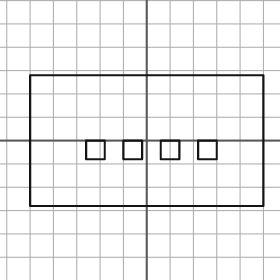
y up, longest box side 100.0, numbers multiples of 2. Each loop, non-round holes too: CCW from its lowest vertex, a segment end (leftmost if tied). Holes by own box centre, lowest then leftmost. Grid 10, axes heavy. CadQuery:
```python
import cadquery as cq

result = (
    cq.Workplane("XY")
    .moveTo(-50.0, -28.0)
    .lineTo(50.0, -28.0)
    .lineTo(50.0, 28.0)
    .lineTo(-50.0, 28.0)
    .close()
    .moveTo(-26.0, -8.0)
    .lineTo(-18.0, -8.0)
    .lineTo(-18.0, 0.0)
    .lineTo(-26.0, 0.0)
    .close()
    .moveTo(-10.0, -8.0)
    .lineTo(-2.0, -8.0)
    .lineTo(-2.0, 0.0)
    .lineTo(-10.0, 0.0)
    .close()
    .moveTo(6.0, -8.0)
    .lineTo(14.0, -8.0)
    .lineTo(14.0, 0.0)
    .lineTo(6.0, 0.0)
    .close()
    .moveTo(22.0, -8.0)
    .lineTo(30.0, -8.0)
    .lineTo(30.0, 0.0)
    .lineTo(22.0, 0.0)
    .close()
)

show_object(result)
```